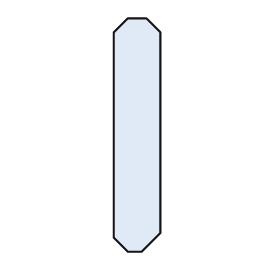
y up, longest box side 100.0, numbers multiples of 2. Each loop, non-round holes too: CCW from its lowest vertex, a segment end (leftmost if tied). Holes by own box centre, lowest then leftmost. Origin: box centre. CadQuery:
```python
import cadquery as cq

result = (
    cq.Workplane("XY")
    .moveTo(-4.0, -50.0)
    .lineTo(2.0, -50.0)
    .lineTo(10.0, -42.0)
    .lineTo(10.0, 44.0)
    .lineTo(4.0, 50.0)
    .lineTo(-4.0, 50.0)
    .lineTo(-10.0, 44.0)
    .lineTo(-10.0, -44.0)
    .close()
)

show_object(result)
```